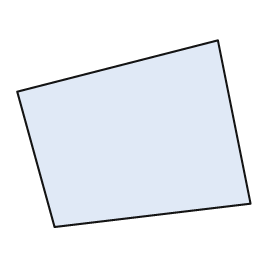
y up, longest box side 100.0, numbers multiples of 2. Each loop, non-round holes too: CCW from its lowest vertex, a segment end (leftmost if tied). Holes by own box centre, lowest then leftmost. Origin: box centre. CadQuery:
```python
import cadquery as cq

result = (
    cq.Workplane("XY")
    .moveTo(-34.0, -40.0)
    .lineTo(50.0, -30.0)
    .lineTo(36.0, 40.0)
    .lineTo(-50.0, 18.0)
    .close()
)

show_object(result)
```